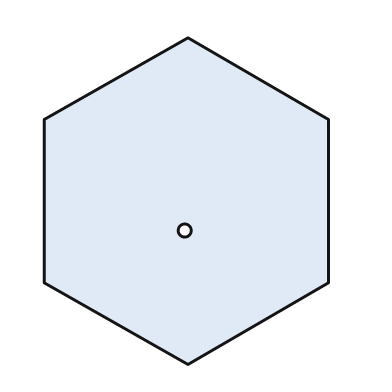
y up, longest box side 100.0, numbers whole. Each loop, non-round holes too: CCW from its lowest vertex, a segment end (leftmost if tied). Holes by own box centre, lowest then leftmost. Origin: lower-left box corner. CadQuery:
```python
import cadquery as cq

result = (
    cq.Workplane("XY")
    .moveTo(44.0, 0.0)
    .lineTo(87.0, 25.0)
    .lineTo(87.0, 75.0)
    .lineTo(44.0, 100.0)
    .lineTo(0.0, 75.0)
    .lineTo(0.0, 25.0)
    .close()
    .moveTo(43.0, 41.0)
    .circle(2.0)
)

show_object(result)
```